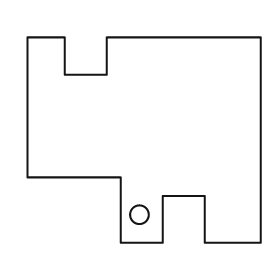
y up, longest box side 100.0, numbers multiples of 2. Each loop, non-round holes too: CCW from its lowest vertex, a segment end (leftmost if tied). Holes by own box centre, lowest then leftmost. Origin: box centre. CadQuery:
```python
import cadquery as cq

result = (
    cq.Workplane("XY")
    .moveTo(-10.0, -44.0)
    .lineTo(8.0, -44.0)
    .lineTo(8.0, -24.0)
    .lineTo(26.0, -24.0)
    .lineTo(26.0, -44.0)
    .lineTo(50.0, -44.0)
    .lineTo(50.0, 44.0)
    .lineTo(-16.0, 44.0)
    .lineTo(-16.0, 28.0)
    .lineTo(-34.0, 28.0)
    .lineTo(-34.0, 44.0)
    .lineTo(-50.0, 44.0)
    .lineTo(-50.0, -16.0)
    .lineTo(-10.0, -16.0)
    .close()
    .moveTo(-2.0, -32.0)
    .circle(4.0)
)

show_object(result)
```